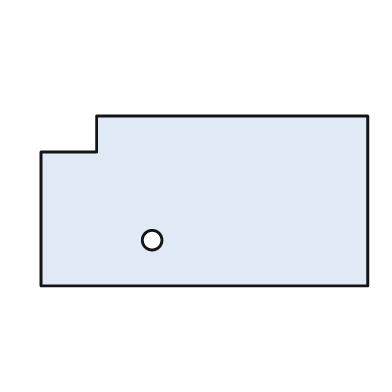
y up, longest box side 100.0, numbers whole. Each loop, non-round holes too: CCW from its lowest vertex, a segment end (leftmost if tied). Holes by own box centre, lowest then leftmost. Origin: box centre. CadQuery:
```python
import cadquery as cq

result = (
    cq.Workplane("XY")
    .moveTo(-50.0, -26.0)
    .lineTo(50.0, -26.0)
    .lineTo(50.0, 26.0)
    .lineTo(-33.0, 26.0)
    .lineTo(-33.0, 15.0)
    .lineTo(-50.0, 15.0)
    .close()
    .moveTo(-16.0, -12.0)
    .circle(3.0)
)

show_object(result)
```